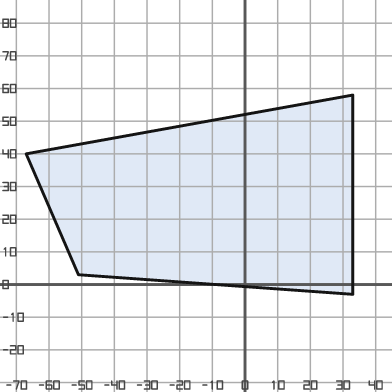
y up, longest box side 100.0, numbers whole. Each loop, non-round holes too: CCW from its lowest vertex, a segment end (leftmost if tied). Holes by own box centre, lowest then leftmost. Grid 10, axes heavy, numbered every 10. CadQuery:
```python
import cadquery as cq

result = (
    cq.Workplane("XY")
    .moveTo(33.0, -3.0)
    .lineTo(33.0, 58.0)
    .lineTo(-67.0, 40.0)
    .lineTo(-51.0, 3.0)
    .close()
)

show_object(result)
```